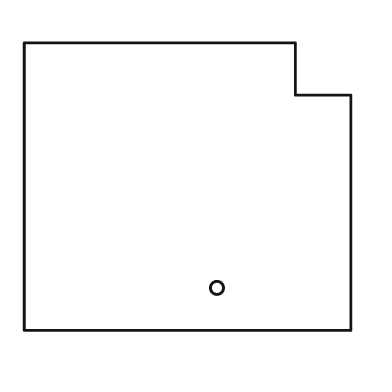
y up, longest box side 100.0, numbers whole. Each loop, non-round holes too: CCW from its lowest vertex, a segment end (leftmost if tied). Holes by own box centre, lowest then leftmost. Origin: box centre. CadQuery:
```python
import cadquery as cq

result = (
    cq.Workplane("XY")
    .moveTo(-50.0, -44.0)
    .lineTo(50.0, -44.0)
    .lineTo(50.0, 28.0)
    .lineTo(33.0, 28.0)
    .lineTo(33.0, 44.0)
    .lineTo(-50.0, 44.0)
    .close()
    .moveTo(9.0, -31.0)
    .circle(2.0)
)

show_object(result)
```